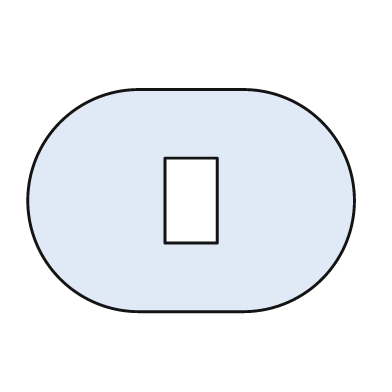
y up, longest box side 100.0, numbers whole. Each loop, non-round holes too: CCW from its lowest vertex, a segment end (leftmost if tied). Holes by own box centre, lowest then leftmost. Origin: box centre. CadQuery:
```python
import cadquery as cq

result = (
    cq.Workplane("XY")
    .moveTo(-16.0, -34.0)
    .lineTo(16.0, -34.0)
    .threePointArc((50.0, 0.0), (16.0, 34.0))
    .lineTo(-16.0, 34.0)
    .threePointArc((-50.0, 0.0), (-16.0, -34.0))
    .close()
    .moveTo(-8.0, -13.0)
    .lineTo(8.0, -13.0)
    .lineTo(8.0, 13.0)
    .lineTo(-8.0, 13.0)
    .close()
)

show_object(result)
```